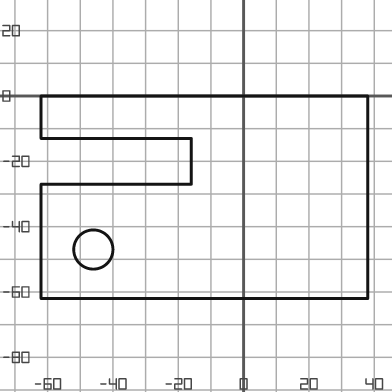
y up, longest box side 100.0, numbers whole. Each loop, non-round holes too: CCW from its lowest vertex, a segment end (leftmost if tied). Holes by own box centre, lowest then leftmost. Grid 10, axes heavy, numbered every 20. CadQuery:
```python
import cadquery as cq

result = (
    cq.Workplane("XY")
    .moveTo(-62.0, -62.0)
    .lineTo(38.0, -62.0)
    .lineTo(38.0, 0.0)
    .lineTo(-62.0, 0.0)
    .lineTo(-62.0, -13.0)
    .lineTo(-16.0, -13.0)
    .lineTo(-16.0, -27.0)
    .lineTo(-62.0, -27.0)
    .close()
    .moveTo(-46.0, -47.0)
    .circle(6.0)
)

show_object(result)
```